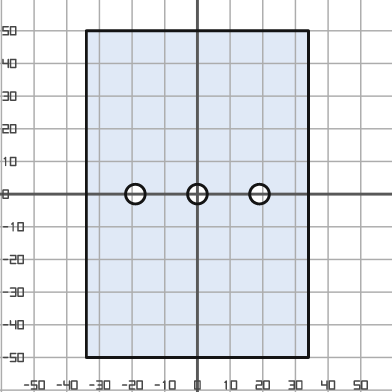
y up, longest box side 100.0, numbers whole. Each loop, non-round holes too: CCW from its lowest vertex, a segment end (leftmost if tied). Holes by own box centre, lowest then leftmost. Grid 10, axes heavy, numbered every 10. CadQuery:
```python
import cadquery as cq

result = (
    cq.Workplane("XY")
    .moveTo(-34.0, -50.0)
    .lineTo(34.0, -50.0)
    .lineTo(34.0, 50.0)
    .lineTo(-34.0, 50.0)
    .close()
    .moveTo(-19.0, 0.0)
    .circle(3.0)
    .moveTo(0.0, 0.0)
    .circle(3.0)
    .moveTo(19.0, 0.0)
    .circle(3.0)
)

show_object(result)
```